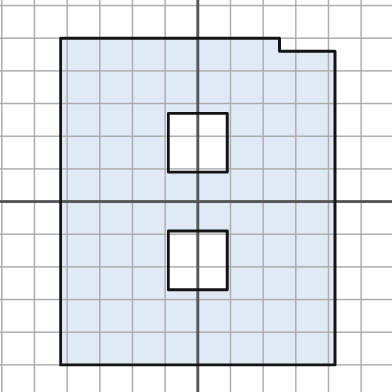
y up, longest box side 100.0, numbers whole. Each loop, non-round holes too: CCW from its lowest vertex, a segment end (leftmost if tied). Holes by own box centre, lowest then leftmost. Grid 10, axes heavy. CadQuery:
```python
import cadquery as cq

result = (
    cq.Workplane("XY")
    .moveTo(-42.0, -50.0)
    .lineTo(42.0, -50.0)
    .lineTo(42.0, 46.0)
    .lineTo(25.0, 46.0)
    .lineTo(25.0, 50.0)
    .lineTo(-42.0, 50.0)
    .close()
    .moveTo(-9.0, -27.0)
    .lineTo(9.0, -27.0)
    .lineTo(9.0, -9.0)
    .lineTo(-9.0, -9.0)
    .close()
    .moveTo(-9.0, 9.0)
    .lineTo(9.0, 9.0)
    .lineTo(9.0, 27.0)
    .lineTo(-9.0, 27.0)
    .close()
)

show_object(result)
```